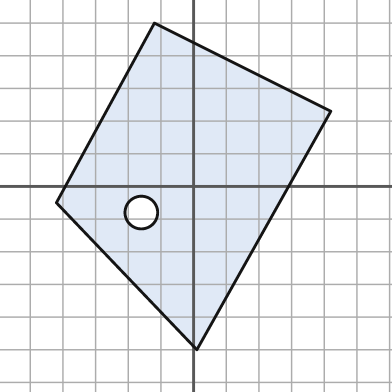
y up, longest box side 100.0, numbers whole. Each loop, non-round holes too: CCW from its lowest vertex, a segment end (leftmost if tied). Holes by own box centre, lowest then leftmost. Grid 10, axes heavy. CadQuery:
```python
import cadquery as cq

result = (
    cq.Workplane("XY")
    .moveTo(1.0, -50.0)
    .lineTo(42.0, 23.0)
    .lineTo(-12.0, 50.0)
    .lineTo(-42.0, -5.0)
    .close()
    .moveTo(-16.0, -8.0)
    .circle(5.0)
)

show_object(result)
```